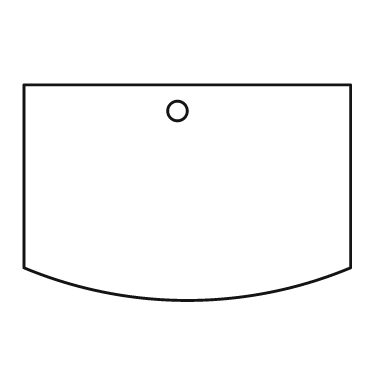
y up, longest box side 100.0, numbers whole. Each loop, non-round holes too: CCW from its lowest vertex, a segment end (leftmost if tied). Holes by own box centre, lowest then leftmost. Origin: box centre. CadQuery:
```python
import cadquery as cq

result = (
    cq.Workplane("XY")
    .moveTo(-50.0, -23.0)
    .threePointArc((0.0, -33.0), (50.0, -23.0))
    .lineTo(50.0, 33.0)
    .lineTo(-50.0, 33.0)
    .close()
    .moveTo(-3.0, 25.0)
    .circle(3.0)
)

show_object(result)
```